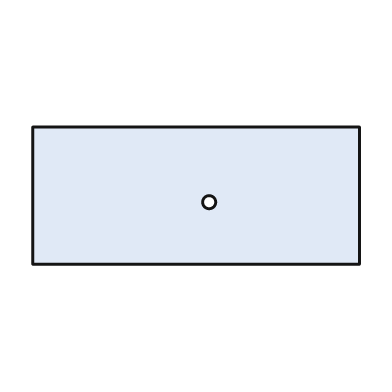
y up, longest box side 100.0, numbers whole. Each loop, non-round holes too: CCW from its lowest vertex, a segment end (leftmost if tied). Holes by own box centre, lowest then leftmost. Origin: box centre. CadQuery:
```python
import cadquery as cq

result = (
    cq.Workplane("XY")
    .moveTo(-50.0, -21.0)
    .lineTo(50.0, -21.0)
    .lineTo(50.0, 21.0)
    .lineTo(-50.0, 21.0)
    .close()
    .moveTo(4.0, -2.0)
    .circle(2.0)
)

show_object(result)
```